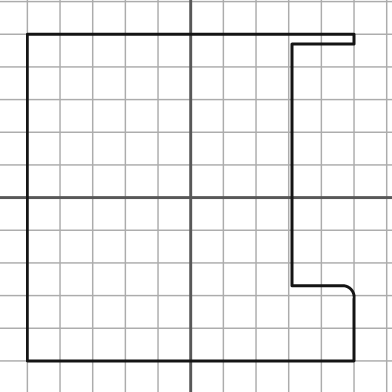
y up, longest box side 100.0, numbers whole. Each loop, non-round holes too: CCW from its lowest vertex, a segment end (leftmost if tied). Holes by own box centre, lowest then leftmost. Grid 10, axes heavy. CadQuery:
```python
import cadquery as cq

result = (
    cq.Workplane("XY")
    .moveTo(-50.0, -50.0)
    .lineTo(50.0, -50.0)
    .lineTo(50.0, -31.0)
    .threePointArc((49.0, -28.0), (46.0, -27.0))
    .lineTo(31.0, -27.0)
    .lineTo(31.0, 47.0)
    .lineTo(50.0, 47.0)
    .lineTo(50.0, 50.0)
    .lineTo(-50.0, 50.0)
    .close()
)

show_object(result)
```